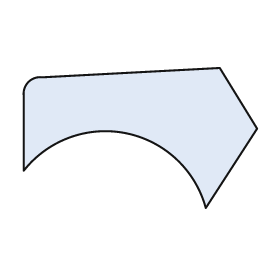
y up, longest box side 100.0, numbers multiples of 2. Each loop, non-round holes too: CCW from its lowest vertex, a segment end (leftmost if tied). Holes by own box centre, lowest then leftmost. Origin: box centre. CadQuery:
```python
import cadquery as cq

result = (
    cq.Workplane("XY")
    .moveTo(28.0, -30.0)
    .lineTo(50.0, 4.0)
    .lineTo(34.0, 30.0)
    .lineTo(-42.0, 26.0)
    .threePointArc((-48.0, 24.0), (-50.0, 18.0))
    .lineTo(-50.0, -14.0)
    .threePointArc((-6.0, 2.0), (28.0, -30.0))
    .close()
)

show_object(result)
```